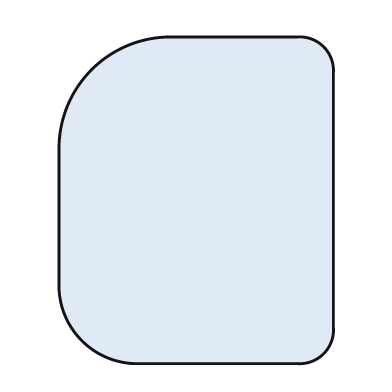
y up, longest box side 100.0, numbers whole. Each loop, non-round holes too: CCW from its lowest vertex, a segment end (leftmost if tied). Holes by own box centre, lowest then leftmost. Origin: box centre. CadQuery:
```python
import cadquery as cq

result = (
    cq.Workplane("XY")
    .moveTo(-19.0, -50.0)
    .lineTo(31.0, -50.0)
    .threePointArc((39.0, -47.0), (42.0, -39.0))
    .lineTo(42.0, 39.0)
    .threePointArc((39.0, 47.0), (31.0, 50.0))
    .lineTo(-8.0, 50.0)
    .threePointArc((-32.0, 40.0), (-42.0, 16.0))
    .lineTo(-42.0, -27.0)
    .threePointArc((-35.0, -43.0), (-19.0, -50.0))
    .close()
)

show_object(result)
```